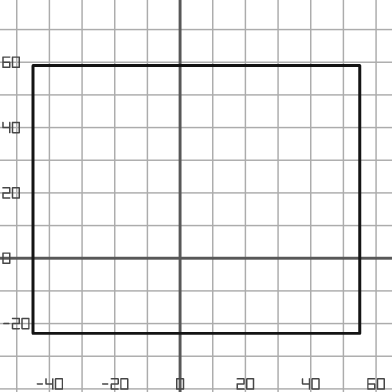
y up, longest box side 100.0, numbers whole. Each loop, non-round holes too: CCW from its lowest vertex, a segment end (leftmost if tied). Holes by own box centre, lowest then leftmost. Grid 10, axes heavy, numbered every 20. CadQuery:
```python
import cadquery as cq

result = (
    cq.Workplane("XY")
    .moveTo(-45.0, -23.0)
    .lineTo(55.0, -23.0)
    .lineTo(55.0, 59.0)
    .lineTo(-45.0, 59.0)
    .close()
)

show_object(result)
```